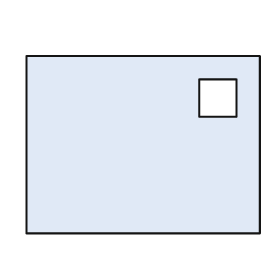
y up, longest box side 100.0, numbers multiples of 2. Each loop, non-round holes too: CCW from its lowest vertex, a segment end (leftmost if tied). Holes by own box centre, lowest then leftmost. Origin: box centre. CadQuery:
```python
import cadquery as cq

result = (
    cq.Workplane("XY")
    .moveTo(-50.0, -38.0)
    .lineTo(50.0, -38.0)
    .lineTo(50.0, 38.0)
    .lineTo(-50.0, 38.0)
    .close()
    .moveTo(24.0, 12.0)
    .lineTo(40.0, 12.0)
    .lineTo(40.0, 28.0)
    .lineTo(24.0, 28.0)
    .close()
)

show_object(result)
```